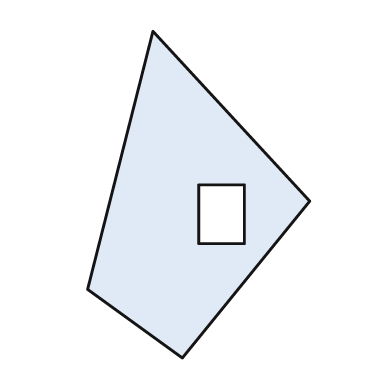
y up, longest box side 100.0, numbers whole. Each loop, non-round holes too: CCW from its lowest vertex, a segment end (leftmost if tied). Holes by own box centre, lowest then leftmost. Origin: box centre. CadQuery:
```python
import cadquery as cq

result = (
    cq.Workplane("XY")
    .moveTo(-5.0, -50.0)
    .lineTo(34.0, -2.0)
    .lineTo(-14.0, 50.0)
    .lineTo(-34.0, -29.0)
    .close()
    .moveTo(0.0, -15.0)
    .lineTo(14.0, -15.0)
    .lineTo(14.0, 3.0)
    .lineTo(0.0, 3.0)
    .close()
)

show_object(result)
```